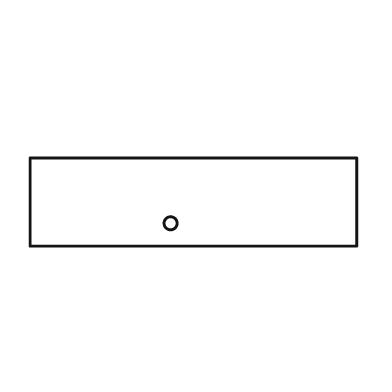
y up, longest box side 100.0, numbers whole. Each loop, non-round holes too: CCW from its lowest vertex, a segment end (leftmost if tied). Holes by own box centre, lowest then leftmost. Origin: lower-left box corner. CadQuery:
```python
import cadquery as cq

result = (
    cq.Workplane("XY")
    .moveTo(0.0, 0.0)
    .lineTo(100.0, 0.0)
    .lineTo(100.0, 27.0)
    .lineTo(0.0, 27.0)
    .close()
    .moveTo(43.0, 7.0)
    .circle(2.0)
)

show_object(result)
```